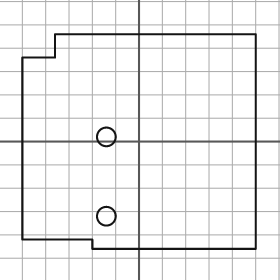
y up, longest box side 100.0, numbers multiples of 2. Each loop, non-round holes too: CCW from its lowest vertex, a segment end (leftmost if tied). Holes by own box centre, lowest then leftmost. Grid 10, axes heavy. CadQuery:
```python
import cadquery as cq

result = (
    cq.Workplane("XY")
    .moveTo(-20.0, -46.0)
    .lineTo(50.0, -46.0)
    .lineTo(50.0, 46.0)
    .lineTo(-36.0, 46.0)
    .lineTo(-36.0, 36.0)
    .lineTo(-50.0, 36.0)
    .lineTo(-50.0, -42.0)
    .lineTo(-20.0, -42.0)
    .close()
    .moveTo(-14.0, -32.0)
    .circle(4.0)
    .moveTo(-14.0, 2.0)
    .circle(4.0)
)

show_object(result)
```